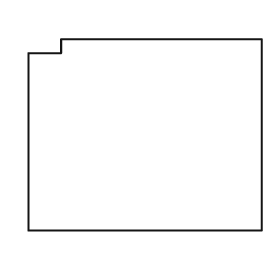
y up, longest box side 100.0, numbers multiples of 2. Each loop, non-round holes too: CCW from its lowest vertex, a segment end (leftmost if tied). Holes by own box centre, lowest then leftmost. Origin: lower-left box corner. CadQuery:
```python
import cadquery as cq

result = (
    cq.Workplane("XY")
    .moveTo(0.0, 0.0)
    .lineTo(100.0, 0.0)
    .lineTo(100.0, 82.0)
    .lineTo(14.0, 82.0)
    .lineTo(14.0, 76.0)
    .lineTo(0.0, 76.0)
    .close()
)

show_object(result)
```